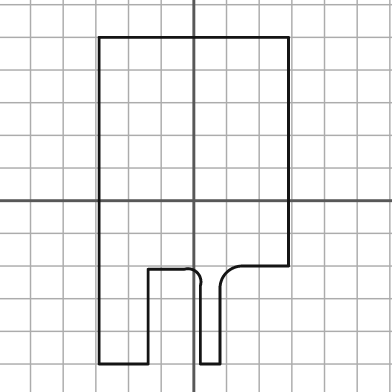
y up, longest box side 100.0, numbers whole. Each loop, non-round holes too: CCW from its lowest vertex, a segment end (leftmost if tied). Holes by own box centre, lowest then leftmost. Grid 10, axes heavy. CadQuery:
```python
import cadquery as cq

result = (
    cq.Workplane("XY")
    .moveTo(-29.0, -50.0)
    .lineTo(-14.0, -50.0)
    .lineTo(-14.0, -21.0)
    .lineTo(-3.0, -21.0)
    .threePointArc((1.0, -22.0), (2.0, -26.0))
    .lineTo(2.0, -50.0)
    .lineTo(8.0, -50.0)
    .lineTo(8.0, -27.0)
    .threePointArc((10.0, -22.0), (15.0, -20.0))
    .lineTo(29.0, -20.0)
    .lineTo(29.0, 50.0)
    .lineTo(-29.0, 50.0)
    .close()
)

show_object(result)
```